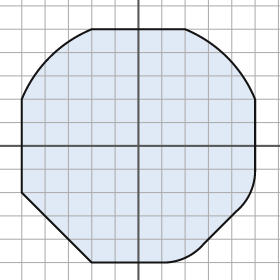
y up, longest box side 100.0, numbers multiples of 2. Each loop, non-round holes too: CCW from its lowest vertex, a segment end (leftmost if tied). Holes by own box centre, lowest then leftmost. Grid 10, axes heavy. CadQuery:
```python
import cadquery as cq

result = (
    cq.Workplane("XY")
    .moveTo(-20.0, -50.0)
    .lineTo(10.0, -50.0)
    .threePointArc((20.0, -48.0), (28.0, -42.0))
    .lineTo(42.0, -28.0)
    .threePointArc((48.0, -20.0), (50.0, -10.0))
    .lineTo(50.0, 20.0)
    .threePointArc((38.0, 38.0), (20.0, 50.0))
    .lineTo(-20.0, 50.0)
    .threePointArc((-38.0, 38.0), (-50.0, 20.0))
    .lineTo(-50.0, -20.0)
    .close()
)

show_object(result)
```